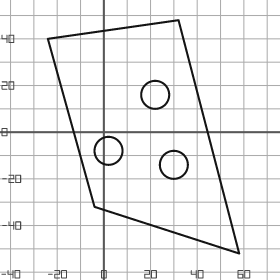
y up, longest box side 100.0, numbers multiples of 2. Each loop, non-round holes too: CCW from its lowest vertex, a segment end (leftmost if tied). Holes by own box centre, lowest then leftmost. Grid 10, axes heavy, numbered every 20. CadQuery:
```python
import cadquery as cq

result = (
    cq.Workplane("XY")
    .moveTo(58.0, -52.0)
    .lineTo(32.0, 48.0)
    .lineTo(-24.0, 40.0)
    .lineTo(-4.0, -32.0)
    .close()
    .moveTo(30.0, -14.0)
    .circle(6.0)
    .moveTo(2.0, -8.0)
    .circle(6.0)
    .moveTo(22.0, 16.0)
    .circle(6.0)
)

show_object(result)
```